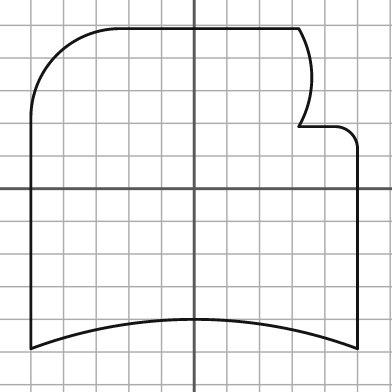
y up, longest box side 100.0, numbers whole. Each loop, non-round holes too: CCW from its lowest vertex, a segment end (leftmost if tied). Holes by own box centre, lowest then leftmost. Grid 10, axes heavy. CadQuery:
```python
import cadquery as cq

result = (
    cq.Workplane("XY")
    .moveTo(-50.0, -49.0)
    .threePointArc((0.0, -40.0), (50.0, -49.0))
    .lineTo(50.0, 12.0)
    .threePointArc((48.0, 17.0), (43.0, 19.0))
    .lineTo(32.0, 19.0)
    .threePointArc((36.0, 34.0), (32.0, 49.0))
    .lineTo(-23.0, 49.0)
    .threePointArc((-42.0, 41.0), (-50.0, 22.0))
    .close()
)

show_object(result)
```